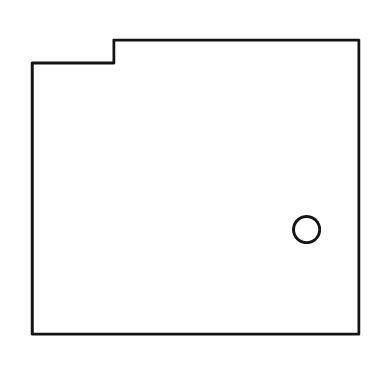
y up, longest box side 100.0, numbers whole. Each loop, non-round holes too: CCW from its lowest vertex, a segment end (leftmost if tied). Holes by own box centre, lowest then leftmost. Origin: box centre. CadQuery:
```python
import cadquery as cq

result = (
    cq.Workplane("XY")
    .moveTo(-50.0, -45.0)
    .lineTo(50.0, -45.0)
    .lineTo(50.0, 45.0)
    .lineTo(-25.0, 45.0)
    .lineTo(-25.0, 38.0)
    .lineTo(-50.0, 38.0)
    .close()
    .moveTo(34.0, -13.0)
    .circle(4.0)
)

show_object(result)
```